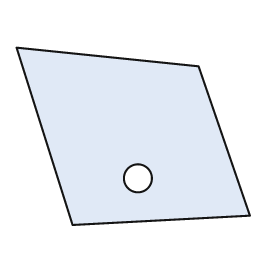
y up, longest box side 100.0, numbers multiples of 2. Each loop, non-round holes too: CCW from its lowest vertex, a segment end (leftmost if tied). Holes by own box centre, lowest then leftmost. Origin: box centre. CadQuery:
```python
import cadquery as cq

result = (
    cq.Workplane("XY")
    .moveTo(-26.0, -38.0)
    .lineTo(50.0, -34.0)
    .lineTo(28.0, 30.0)
    .lineTo(-50.0, 38.0)
    .close()
    .moveTo(2.0, -18.0)
    .circle(6.0)
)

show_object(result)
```